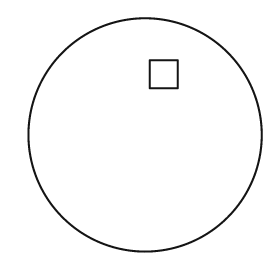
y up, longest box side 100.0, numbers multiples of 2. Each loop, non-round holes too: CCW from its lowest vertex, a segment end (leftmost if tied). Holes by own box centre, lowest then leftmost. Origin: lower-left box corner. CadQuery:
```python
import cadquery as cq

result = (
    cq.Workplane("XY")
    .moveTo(50.0, 50.0)
    .circle(50.0)
    .moveTo(52.0, 70.0)
    .lineTo(64.0, 70.0)
    .lineTo(64.0, 82.0)
    .lineTo(52.0, 82.0)
    .close()
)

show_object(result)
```